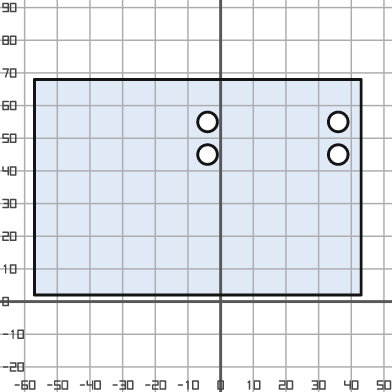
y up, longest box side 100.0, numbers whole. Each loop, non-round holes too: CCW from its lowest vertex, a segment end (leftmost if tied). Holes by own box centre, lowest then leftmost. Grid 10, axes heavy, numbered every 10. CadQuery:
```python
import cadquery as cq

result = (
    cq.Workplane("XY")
    .moveTo(-57.0, 2.0)
    .lineTo(43.0, 2.0)
    .lineTo(43.0, 68.0)
    .lineTo(-57.0, 68.0)
    .close()
    .moveTo(-4.0, 45.0)
    .circle(3.0)
    .moveTo(36.0, 45.0)
    .circle(3.0)
    .moveTo(-4.0, 55.0)
    .circle(3.0)
    .moveTo(36.0, 55.0)
    .circle(3.0)
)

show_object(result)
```